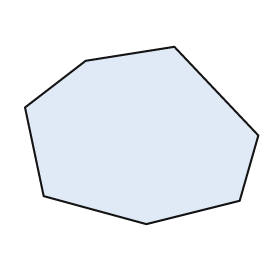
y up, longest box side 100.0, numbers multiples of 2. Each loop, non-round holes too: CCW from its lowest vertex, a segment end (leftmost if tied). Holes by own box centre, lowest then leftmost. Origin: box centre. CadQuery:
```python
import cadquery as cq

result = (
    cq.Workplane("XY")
    .moveTo(2.0, -38.0)
    .lineTo(42.0, -28.0)
    .lineTo(50.0, 0.0)
    .lineTo(14.0, 38.0)
    .lineTo(-24.0, 32.0)
    .lineTo(-50.0, 12.0)
    .lineTo(-42.0, -26.0)
    .close()
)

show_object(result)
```